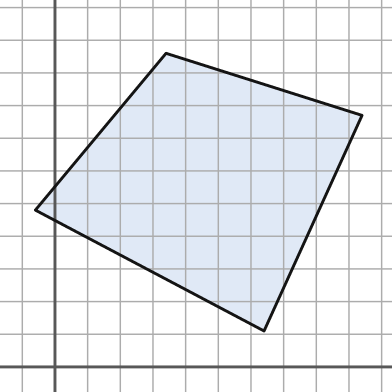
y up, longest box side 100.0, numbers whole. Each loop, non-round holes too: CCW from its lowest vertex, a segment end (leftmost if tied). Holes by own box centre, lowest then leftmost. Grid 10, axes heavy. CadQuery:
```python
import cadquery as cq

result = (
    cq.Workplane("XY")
    .moveTo(64.0, 11.0)
    .lineTo(94.0, 77.0)
    .lineTo(34.0, 96.0)
    .lineTo(-6.0, 48.0)
    .close()
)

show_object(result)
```